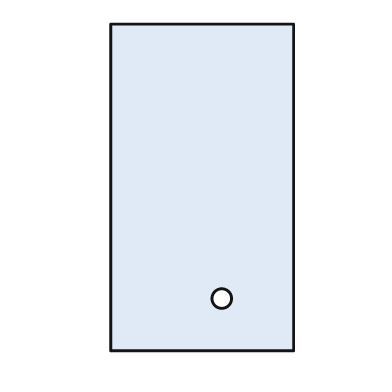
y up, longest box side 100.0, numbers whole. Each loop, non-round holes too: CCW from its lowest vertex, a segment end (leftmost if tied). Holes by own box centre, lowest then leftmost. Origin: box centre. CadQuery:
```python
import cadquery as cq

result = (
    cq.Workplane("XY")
    .moveTo(-28.0, -50.0)
    .lineTo(28.0, -50.0)
    .lineTo(28.0, 50.0)
    .lineTo(-28.0, 50.0)
    .close()
    .moveTo(6.0, -34.0)
    .circle(3.0)
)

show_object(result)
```